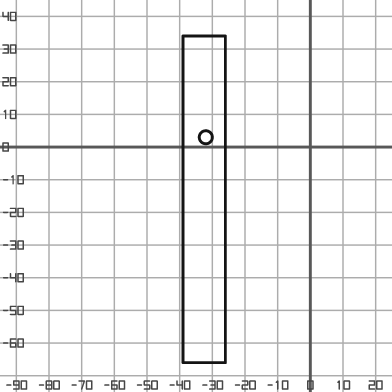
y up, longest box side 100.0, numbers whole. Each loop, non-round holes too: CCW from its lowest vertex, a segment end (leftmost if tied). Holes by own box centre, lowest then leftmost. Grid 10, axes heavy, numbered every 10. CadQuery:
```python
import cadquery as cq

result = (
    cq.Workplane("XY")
    .moveTo(-39.0, -66.0)
    .lineTo(-26.0, -66.0)
    .lineTo(-26.0, 34.0)
    .lineTo(-39.0, 34.0)
    .close()
    .moveTo(-32.0, 3.0)
    .circle(2.0)
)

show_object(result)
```